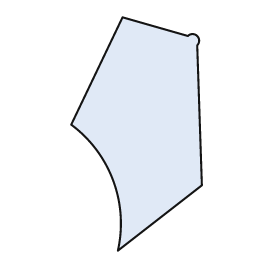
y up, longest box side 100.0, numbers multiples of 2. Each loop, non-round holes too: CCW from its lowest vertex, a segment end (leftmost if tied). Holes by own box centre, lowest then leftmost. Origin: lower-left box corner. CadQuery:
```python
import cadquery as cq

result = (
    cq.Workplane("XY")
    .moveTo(20.0, 0.0)
    .lineTo(56.0, 28.0)
    .lineTo(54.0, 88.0)
    .threePointArc((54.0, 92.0), (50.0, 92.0))
    .lineTo(22.0, 100.0)
    .lineTo(0.0, 54.0)
    .threePointArc((18.0, 30.0), (20.0, 0.0))
    .close()
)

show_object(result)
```